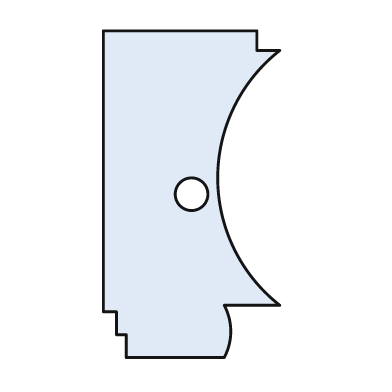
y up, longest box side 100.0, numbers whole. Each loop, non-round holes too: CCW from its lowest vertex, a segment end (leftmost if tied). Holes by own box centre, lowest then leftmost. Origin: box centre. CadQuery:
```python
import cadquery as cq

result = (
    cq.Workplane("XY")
    .moveTo(-20.0, -50.0)
    .lineTo(10.0, -50.0)
    .threePointArc((12.0, -42.0), (10.0, -34.0))
    .lineTo(27.0, -34.0)
    .threePointArc((8.0, 5.0), (27.0, 44.0))
    .lineTo(20.0, 44.0)
    .lineTo(20.0, 50.0)
    .lineTo(-27.0, 50.0)
    .lineTo(-27.0, -36.0)
    .lineTo(-23.0, -36.0)
    .lineTo(-23.0, -43.0)
    .lineTo(-20.0, -43.0)
    .close()
    .moveTo(0.0, 0.0)
    .circle(5.0)
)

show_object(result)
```